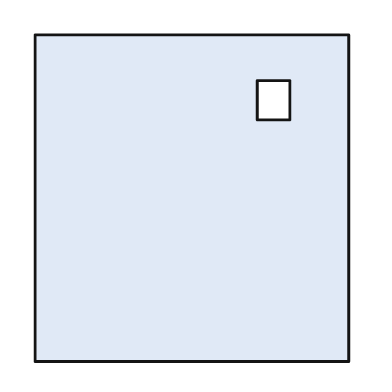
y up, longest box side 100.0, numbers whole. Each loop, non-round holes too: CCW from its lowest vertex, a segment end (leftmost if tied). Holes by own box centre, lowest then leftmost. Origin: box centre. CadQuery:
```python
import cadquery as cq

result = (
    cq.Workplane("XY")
    .moveTo(-48.0, -50.0)
    .lineTo(48.0, -50.0)
    .lineTo(48.0, 50.0)
    .lineTo(-48.0, 50.0)
    .close()
    .moveTo(20.0, 24.0)
    .lineTo(30.0, 24.0)
    .lineTo(30.0, 36.0)
    .lineTo(20.0, 36.0)
    .close()
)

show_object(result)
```